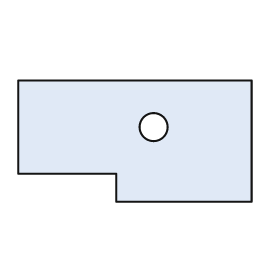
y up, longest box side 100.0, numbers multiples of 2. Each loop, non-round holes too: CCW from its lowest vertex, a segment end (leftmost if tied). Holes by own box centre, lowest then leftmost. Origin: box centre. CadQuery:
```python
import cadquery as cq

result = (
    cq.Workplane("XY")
    .moveTo(-8.0, -26.0)
    .lineTo(50.0, -26.0)
    .lineTo(50.0, 26.0)
    .lineTo(-50.0, 26.0)
    .lineTo(-50.0, -14.0)
    .lineTo(-8.0, -14.0)
    .close()
    .moveTo(8.0, 6.0)
    .circle(6.0)
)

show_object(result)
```